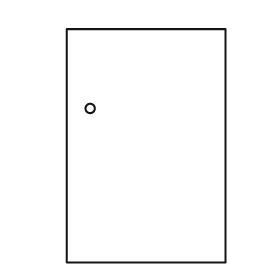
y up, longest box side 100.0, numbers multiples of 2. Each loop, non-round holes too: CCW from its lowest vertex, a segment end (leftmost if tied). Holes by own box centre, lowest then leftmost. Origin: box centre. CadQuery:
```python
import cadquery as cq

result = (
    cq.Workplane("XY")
    .moveTo(-34.0, -50.0)
    .lineTo(34.0, -50.0)
    .lineTo(34.0, 50.0)
    .lineTo(-34.0, 50.0)
    .close()
    .moveTo(-24.0, 16.0)
    .circle(2.0)
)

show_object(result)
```